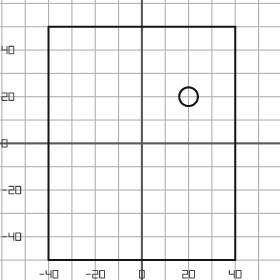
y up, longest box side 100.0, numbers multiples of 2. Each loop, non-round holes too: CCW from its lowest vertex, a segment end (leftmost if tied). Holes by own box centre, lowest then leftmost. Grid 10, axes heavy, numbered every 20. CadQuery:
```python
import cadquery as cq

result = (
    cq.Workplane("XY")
    .moveTo(-40.0, -50.0)
    .lineTo(40.0, -50.0)
    .lineTo(40.0, 50.0)
    .lineTo(-40.0, 50.0)
    .close()
    .moveTo(20.0, 20.0)
    .circle(4.0)
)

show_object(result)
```